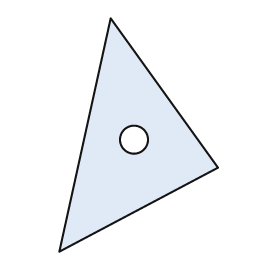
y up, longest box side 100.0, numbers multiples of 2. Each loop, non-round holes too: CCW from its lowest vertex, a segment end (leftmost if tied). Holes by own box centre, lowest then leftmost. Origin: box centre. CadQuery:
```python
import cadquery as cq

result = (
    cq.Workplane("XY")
    .moveTo(-34.0, -50.0)
    .lineTo(34.0, -14.0)
    .lineTo(-12.0, 50.0)
    .close()
    .moveTo(-2.0, -2.0)
    .circle(6.0)
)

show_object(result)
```